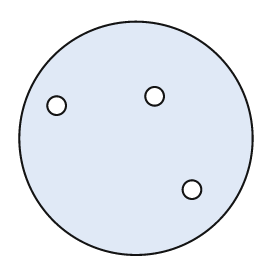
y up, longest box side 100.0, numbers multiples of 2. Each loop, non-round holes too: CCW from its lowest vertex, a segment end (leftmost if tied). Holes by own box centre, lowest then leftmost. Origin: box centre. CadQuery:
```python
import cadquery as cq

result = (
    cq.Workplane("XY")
    .moveTo(0.0, 0.0)
    .circle(50.0)
    .moveTo(24.0, -22.0)
    .circle(4.0)
    .moveTo(-34.0, 14.0)
    .circle(4.0)
    .moveTo(8.0, 18.0)
    .circle(4.0)
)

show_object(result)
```